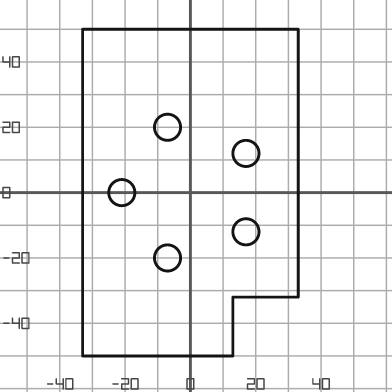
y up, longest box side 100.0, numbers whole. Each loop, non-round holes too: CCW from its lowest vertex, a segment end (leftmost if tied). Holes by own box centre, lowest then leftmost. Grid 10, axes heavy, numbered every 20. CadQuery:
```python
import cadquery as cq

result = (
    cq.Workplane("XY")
    .moveTo(-33.0, -50.0)
    .lineTo(13.0, -50.0)
    .lineTo(13.0, -32.0)
    .lineTo(33.0, -32.0)
    .lineTo(33.0, 50.0)
    .lineTo(-33.0, 50.0)
    .close()
    .moveTo(-7.0, -20.0)
    .circle(4.0)
    .moveTo(17.0, -12.0)
    .circle(4.0)
    .moveTo(-21.0, 0.0)
    .circle(4.0)
    .moveTo(17.0, 12.0)
    .circle(4.0)
    .moveTo(-7.0, 20.0)
    .circle(4.0)
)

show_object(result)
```